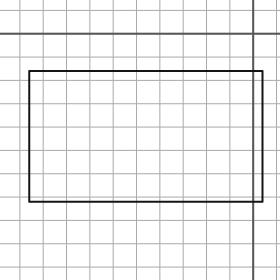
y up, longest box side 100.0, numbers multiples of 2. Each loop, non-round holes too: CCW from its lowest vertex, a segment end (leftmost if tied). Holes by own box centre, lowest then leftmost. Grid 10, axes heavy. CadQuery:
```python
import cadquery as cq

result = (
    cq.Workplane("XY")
    .moveTo(-96.0, -72.0)
    .lineTo(4.0, -72.0)
    .lineTo(4.0, -16.0)
    .lineTo(-96.0, -16.0)
    .close()
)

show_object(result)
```